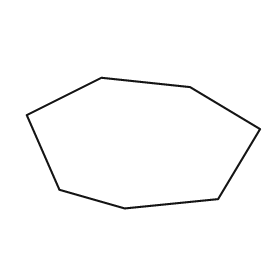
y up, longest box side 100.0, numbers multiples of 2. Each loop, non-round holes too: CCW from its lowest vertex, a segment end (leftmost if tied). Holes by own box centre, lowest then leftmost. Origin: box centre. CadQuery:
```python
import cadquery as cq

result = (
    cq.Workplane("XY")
    .moveTo(-8.0, -28.0)
    .lineTo(32.0, -24.0)
    .lineTo(50.0, 6.0)
    .lineTo(20.0, 24.0)
    .lineTo(-18.0, 28.0)
    .lineTo(-50.0, 12.0)
    .lineTo(-36.0, -20.0)
    .close()
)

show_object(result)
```